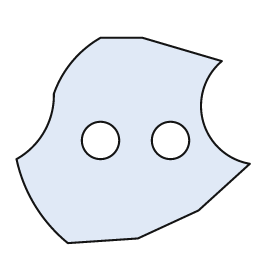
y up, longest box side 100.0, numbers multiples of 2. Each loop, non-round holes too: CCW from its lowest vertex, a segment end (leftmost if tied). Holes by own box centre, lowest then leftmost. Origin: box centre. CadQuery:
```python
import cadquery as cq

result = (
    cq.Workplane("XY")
    .moveTo(-28.0, -44.0)
    .lineTo(2.0, -42.0)
    .lineTo(28.0, -30.0)
    .lineTo(50.0, -10.0)
    .threePointArc((30.0, 8.0), (38.0, 34.0))
    .lineTo(4.0, 44.0)
    .lineTo(-14.0, 44.0)
    .threePointArc((-26.0, 34.0), (-34.0, 20.0))
    .threePointArc((-38.0, 4.0), (-50.0, -8.0))
    .threePointArc((-42.0, -28.0), (-28.0, -44.0))
    .close()
    .moveTo(-14.0, 0.0)
    .circle(8.0)
    .moveTo(16.0, 0.0)
    .circle(8.0)
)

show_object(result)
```